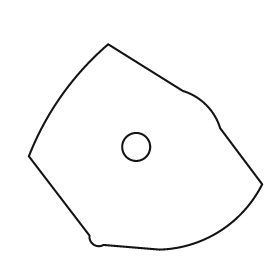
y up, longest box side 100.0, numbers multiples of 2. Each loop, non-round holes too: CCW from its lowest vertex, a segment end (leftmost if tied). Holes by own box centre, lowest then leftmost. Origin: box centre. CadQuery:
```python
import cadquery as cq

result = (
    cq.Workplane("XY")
    .moveTo(6.0, -44.0)
    .threePointArc((32.0, -36.0), (50.0, -16.0))
    .lineTo(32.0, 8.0)
    .threePointArc((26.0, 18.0), (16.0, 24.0))
    .lineTo(-16.0, 44.0)
    .threePointArc((-36.0, 22.0), (-50.0, -4.0))
    .lineTo(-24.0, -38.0)
    .threePointArc((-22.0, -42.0), (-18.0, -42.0))
    .close()
    .moveTo(-4.0, 0.0)
    .circle(6.0)
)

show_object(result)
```